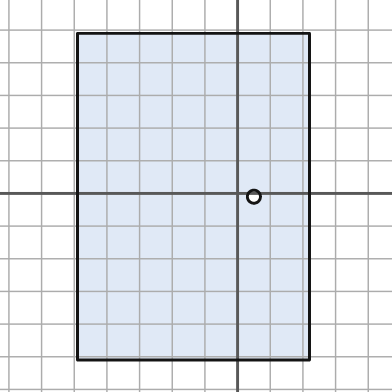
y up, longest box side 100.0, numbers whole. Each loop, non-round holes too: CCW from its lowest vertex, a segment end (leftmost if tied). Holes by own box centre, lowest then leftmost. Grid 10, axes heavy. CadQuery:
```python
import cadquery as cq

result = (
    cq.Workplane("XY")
    .moveTo(-49.0, -51.0)
    .lineTo(22.0, -51.0)
    .lineTo(22.0, 49.0)
    .lineTo(-49.0, 49.0)
    .close()
    .moveTo(5.0, -1.0)
    .circle(2.0)
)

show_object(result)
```